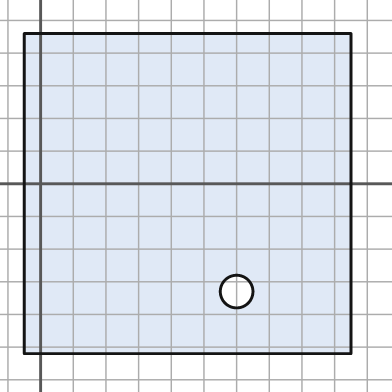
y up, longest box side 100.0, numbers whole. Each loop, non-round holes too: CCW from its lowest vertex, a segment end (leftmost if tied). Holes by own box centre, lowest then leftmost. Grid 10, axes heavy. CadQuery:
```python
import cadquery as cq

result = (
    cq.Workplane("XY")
    .moveTo(-5.0, -52.0)
    .lineTo(95.0, -52.0)
    .lineTo(95.0, 46.0)
    .lineTo(-5.0, 46.0)
    .close()
    .moveTo(60.0, -33.0)
    .circle(5.0)
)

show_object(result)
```